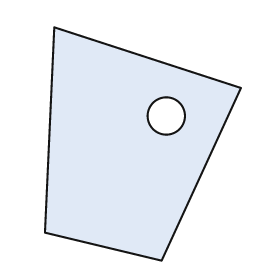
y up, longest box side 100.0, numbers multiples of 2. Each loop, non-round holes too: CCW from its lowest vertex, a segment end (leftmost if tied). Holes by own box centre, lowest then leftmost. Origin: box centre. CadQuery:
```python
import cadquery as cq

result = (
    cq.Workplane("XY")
    .moveTo(8.0, -50.0)
    .lineTo(42.0, 24.0)
    .lineTo(-38.0, 50.0)
    .lineTo(-42.0, -38.0)
    .close()
    .moveTo(10.0, 12.0)
    .circle(8.0)
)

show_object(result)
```